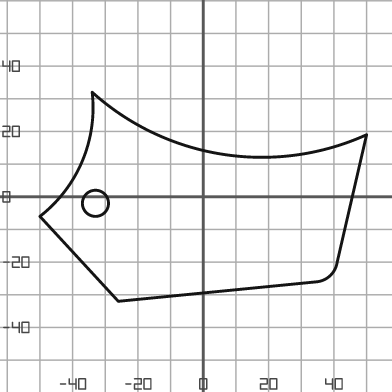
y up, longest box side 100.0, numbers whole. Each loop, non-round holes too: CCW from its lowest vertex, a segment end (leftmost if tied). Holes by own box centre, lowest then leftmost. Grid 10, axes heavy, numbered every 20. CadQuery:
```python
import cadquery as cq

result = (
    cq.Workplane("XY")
    .moveTo(-26.0, -32.0)
    .lineTo(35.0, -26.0)
    .threePointArc((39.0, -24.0), (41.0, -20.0))
    .lineTo(50.0, 19.0)
    .threePointArc((6.0, 13.0), (-34.0, 32.0))
    .threePointArc((-37.0, 11.0), (-50.0, -6.0))
    .close()
    .moveTo(-33.0, -2.0)
    .circle(4.0)
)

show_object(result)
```